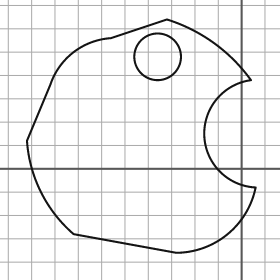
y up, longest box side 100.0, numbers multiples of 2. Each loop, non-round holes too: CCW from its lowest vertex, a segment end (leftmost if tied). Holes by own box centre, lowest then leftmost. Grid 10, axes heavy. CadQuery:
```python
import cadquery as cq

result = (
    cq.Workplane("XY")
    .moveTo(-28.0, -36.0)
    .threePointArc((-6.0, -28.0), (6.0, -8.0))
    .threePointArc((-16.0, 14.0), (4.0, 38.0))
    .threePointArc((-12.0, 54.0), (-32.0, 64.0))
    .lineTo(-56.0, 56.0)
    .threePointArc((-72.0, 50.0), (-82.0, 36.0))
    .lineTo(-92.0, 12.0)
    .threePointArc((-86.0, -10.0), (-72.0, -28.0))
    .close()
    .moveTo(-36.0, 48.0)
    .circle(10.0)
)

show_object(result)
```